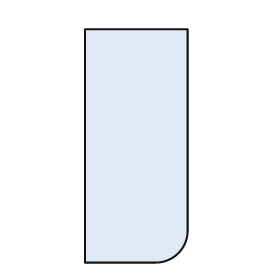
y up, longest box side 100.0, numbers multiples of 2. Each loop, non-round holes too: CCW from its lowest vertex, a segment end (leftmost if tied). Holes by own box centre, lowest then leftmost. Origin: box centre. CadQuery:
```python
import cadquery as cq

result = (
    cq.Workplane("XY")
    .moveTo(-22.0, -50.0)
    .lineTo(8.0, -50.0)
    .threePointArc((18.0, -46.0), (22.0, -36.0))
    .lineTo(22.0, 50.0)
    .lineTo(-22.0, 50.0)
    .close()
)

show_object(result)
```